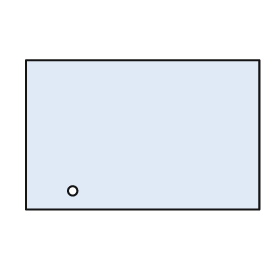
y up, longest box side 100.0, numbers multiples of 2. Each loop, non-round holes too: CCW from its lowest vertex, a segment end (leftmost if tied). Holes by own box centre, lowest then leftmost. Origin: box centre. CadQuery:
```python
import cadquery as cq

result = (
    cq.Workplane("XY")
    .moveTo(-50.0, -32.0)
    .lineTo(50.0, -32.0)
    .lineTo(50.0, 32.0)
    .lineTo(-50.0, 32.0)
    .close()
    .moveTo(-30.0, -24.0)
    .circle(2.0)
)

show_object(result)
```